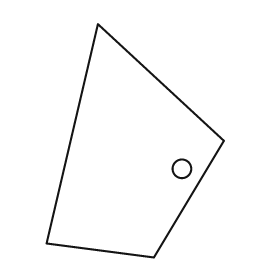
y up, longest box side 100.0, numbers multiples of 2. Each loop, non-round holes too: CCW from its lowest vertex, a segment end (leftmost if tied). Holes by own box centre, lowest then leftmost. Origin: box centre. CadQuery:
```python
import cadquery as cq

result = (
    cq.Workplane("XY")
    .moveTo(8.0, -50.0)
    .lineTo(38.0, 0.0)
    .lineTo(-16.0, 50.0)
    .lineTo(-38.0, -44.0)
    .close()
    .moveTo(20.0, -12.0)
    .circle(4.0)
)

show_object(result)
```